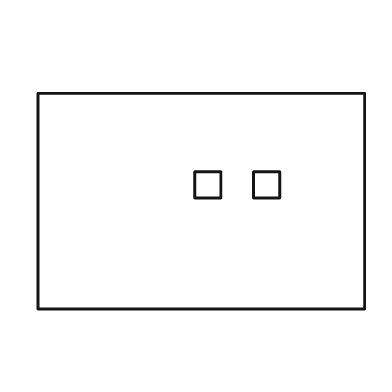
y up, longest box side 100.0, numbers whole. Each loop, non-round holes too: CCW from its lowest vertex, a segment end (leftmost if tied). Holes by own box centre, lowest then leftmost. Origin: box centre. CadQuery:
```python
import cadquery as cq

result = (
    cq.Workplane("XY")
    .moveTo(-50.0, -33.0)
    .lineTo(50.0, -33.0)
    .lineTo(50.0, 33.0)
    .lineTo(-50.0, 33.0)
    .close()
    .moveTo(-2.0, 1.0)
    .lineTo(6.0, 1.0)
    .lineTo(6.0, 9.0)
    .lineTo(-2.0, 9.0)
    .close()
    .moveTo(16.0, 1.0)
    .lineTo(24.0, 1.0)
    .lineTo(24.0, 9.0)
    .lineTo(16.0, 9.0)
    .close()
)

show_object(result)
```